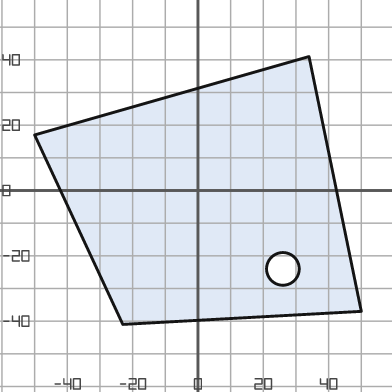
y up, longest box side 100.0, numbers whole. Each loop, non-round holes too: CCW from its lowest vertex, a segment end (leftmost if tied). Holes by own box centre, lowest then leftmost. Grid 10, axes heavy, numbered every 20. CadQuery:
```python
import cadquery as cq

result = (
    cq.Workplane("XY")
    .moveTo(-23.0, -41.0)
    .lineTo(50.0, -37.0)
    .lineTo(34.0, 41.0)
    .lineTo(-50.0, 17.0)
    .close()
    .moveTo(26.0, -24.0)
    .circle(5.0)
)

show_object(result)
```